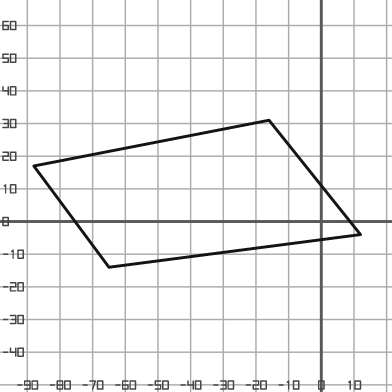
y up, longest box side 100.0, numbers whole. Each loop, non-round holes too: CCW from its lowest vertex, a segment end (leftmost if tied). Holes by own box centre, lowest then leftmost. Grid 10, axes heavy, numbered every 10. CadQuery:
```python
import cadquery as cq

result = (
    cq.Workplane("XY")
    .moveTo(-65.0, -14.0)
    .lineTo(12.0, -4.0)
    .lineTo(-16.0, 31.0)
    .lineTo(-88.0, 17.0)
    .close()
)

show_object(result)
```